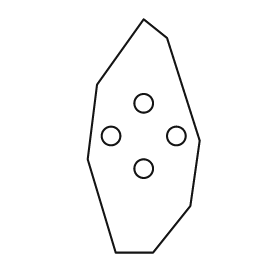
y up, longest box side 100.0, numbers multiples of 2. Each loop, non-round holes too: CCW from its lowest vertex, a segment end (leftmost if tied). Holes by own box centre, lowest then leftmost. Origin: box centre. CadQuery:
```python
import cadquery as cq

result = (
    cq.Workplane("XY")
    .moveTo(-12.0, -50.0)
    .lineTo(4.0, -50.0)
    .lineTo(20.0, -30.0)
    .lineTo(24.0, -2.0)
    .lineTo(10.0, 42.0)
    .lineTo(0.0, 50.0)
    .lineTo(-20.0, 22.0)
    .lineTo(-24.0, -10.0)
    .close()
    .moveTo(0.0, -14.0)
    .circle(4.0)
    .moveTo(-14.0, 0.0)
    .circle(4.0)
    .moveTo(14.0, 0.0)
    .circle(4.0)
    .moveTo(0.0, 14.0)
    .circle(4.0)
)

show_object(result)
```